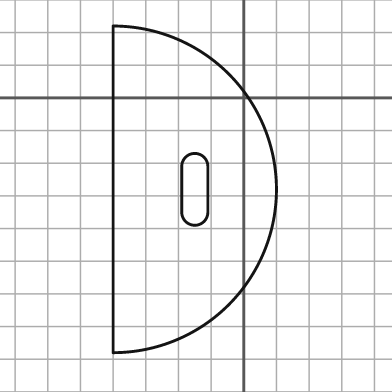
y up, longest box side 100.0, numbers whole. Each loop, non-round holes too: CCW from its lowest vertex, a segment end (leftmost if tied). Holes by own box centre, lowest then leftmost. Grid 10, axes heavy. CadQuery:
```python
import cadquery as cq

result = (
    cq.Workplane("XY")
    .moveTo(-40.0, -78.0)
    .threePointArc((10.0, -28.0), (-40.0, 22.0))
    .close()
    .moveTo(-19.0, -35.0)
    .threePointArc((-15.0, -39.0), (-11.0, -35.0))
    .lineTo(-11.0, -21.0)
    .threePointArc((-15.0, -17.0), (-19.0, -21.0))
    .close()
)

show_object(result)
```